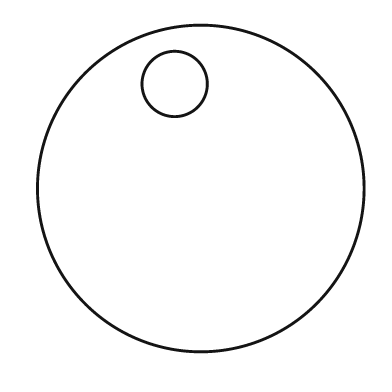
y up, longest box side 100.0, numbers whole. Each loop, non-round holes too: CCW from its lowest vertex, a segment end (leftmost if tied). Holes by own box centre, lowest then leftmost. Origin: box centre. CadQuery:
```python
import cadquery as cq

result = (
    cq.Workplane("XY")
    .moveTo(0.0, 0.0)
    .circle(50.0)
    .moveTo(-8.0, 32.0)
    .circle(10.0)
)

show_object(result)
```